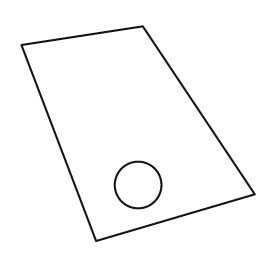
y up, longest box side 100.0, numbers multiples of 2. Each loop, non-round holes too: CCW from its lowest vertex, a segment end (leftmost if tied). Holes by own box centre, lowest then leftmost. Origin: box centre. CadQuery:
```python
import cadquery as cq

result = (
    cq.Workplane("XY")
    .moveTo(-18.0, -46.0)
    .lineTo(50.0, -26.0)
    .lineTo(2.0, 46.0)
    .lineTo(-50.0, 38.0)
    .close()
    .moveTo(0.0, -22.0)
    .circle(10.0)
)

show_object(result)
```